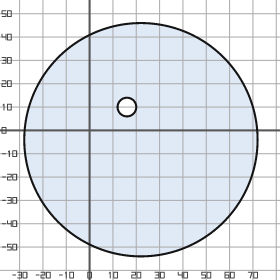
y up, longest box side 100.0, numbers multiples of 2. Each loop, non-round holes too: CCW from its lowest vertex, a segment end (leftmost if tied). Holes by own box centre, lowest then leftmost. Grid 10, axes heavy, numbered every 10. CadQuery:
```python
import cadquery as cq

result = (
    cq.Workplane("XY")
    .moveTo(22.0, -4.0)
    .circle(50.0)
    .moveTo(16.0, 10.0)
    .circle(4.0)
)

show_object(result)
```